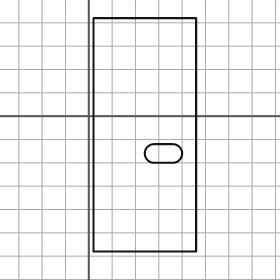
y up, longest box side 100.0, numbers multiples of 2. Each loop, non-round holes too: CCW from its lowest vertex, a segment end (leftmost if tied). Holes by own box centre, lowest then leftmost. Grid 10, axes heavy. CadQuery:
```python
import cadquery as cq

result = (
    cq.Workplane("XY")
    .moveTo(2.0, -58.0)
    .lineTo(46.0, -58.0)
    .lineTo(46.0, 42.0)
    .lineTo(2.0, 42.0)
    .close()
    .moveTo(28.0, -20.0)
    .lineTo(36.0, -20.0)
    .threePointArc((40.0, -16.0), (36.0, -12.0))
    .lineTo(28.0, -12.0)
    .threePointArc((24.0, -16.0), (28.0, -20.0))
    .close()
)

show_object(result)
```